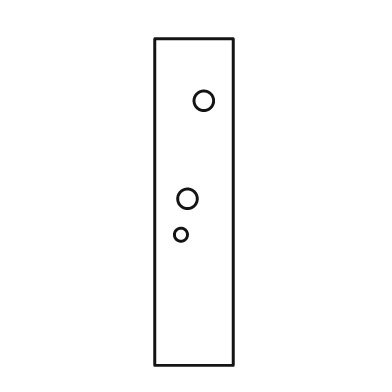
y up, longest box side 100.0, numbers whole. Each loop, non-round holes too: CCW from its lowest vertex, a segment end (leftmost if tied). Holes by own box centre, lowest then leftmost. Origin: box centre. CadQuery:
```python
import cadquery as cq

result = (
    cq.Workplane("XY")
    .moveTo(-12.0, -50.0)
    .lineTo(12.0, -50.0)
    .lineTo(12.0, 50.0)
    .lineTo(-12.0, 50.0)
    .close()
    .moveTo(-4.0, -10.0)
    .circle(2.0)
    .moveTo(-2.0, 1.0)
    .circle(3.0)
    .moveTo(3.0, 31.0)
    .circle(3.0)
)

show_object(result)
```